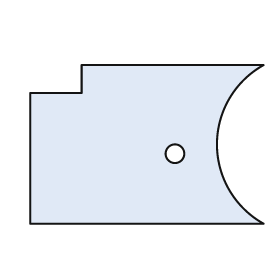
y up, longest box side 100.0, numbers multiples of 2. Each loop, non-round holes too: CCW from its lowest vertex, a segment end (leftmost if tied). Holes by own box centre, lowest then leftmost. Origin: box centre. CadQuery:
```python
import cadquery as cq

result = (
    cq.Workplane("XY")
    .moveTo(-50.0, -34.0)
    .lineTo(50.0, -34.0)
    .threePointArc((30.0, 0.0), (50.0, 34.0))
    .lineTo(-28.0, 34.0)
    .lineTo(-28.0, 22.0)
    .lineTo(-50.0, 22.0)
    .close()
    .moveTo(12.0, -4.0)
    .circle(4.0)
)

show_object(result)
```